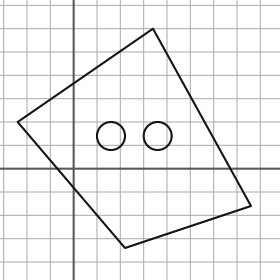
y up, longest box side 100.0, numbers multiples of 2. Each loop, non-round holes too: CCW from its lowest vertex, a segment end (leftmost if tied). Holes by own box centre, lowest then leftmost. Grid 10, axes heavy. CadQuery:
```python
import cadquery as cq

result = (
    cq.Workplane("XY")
    .moveTo(22.0, -34.0)
    .lineTo(76.0, -16.0)
    .lineTo(34.0, 60.0)
    .lineTo(-24.0, 20.0)
    .close()
    .moveTo(16.0, 14.0)
    .circle(6.0)
    .moveTo(36.0, 14.0)
    .circle(6.0)
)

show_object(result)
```